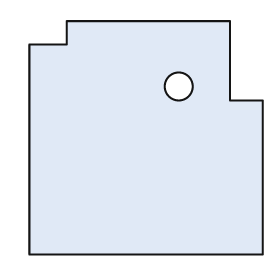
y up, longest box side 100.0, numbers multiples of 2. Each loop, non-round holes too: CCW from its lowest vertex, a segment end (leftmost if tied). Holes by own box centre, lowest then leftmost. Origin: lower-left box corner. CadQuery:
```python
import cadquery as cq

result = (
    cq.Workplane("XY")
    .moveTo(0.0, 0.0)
    .lineTo(100.0, 0.0)
    .lineTo(100.0, 66.0)
    .lineTo(86.0, 66.0)
    .lineTo(86.0, 100.0)
    .lineTo(16.0, 100.0)
    .lineTo(16.0, 90.0)
    .lineTo(0.0, 90.0)
    .close()
    .moveTo(64.0, 72.0)
    .circle(6.0)
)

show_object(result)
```